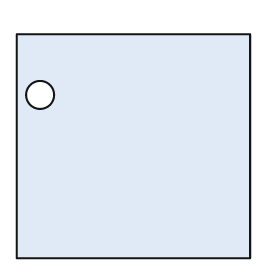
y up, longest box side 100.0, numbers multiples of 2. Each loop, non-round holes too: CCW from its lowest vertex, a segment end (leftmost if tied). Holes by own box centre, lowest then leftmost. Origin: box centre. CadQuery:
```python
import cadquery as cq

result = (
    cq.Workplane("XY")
    .moveTo(-50.0, -48.0)
    .lineTo(50.0, -48.0)
    .lineTo(50.0, 48.0)
    .lineTo(-50.0, 48.0)
    .close()
    .moveTo(-40.0, 22.0)
    .circle(6.0)
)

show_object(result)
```